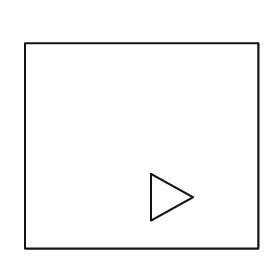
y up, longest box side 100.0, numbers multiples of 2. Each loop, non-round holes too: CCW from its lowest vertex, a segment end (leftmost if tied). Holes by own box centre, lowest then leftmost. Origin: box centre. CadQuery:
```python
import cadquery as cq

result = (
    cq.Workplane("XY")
    .moveTo(-50.0, -44.0)
    .lineTo(50.0, -44.0)
    .lineTo(50.0, 44.0)
    .lineTo(-50.0, 44.0)
    .close()
    .moveTo(4.0, -32.0)
    .lineTo(22.0, -22.0)
    .lineTo(4.0, -12.0)
    .close()
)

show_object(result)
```